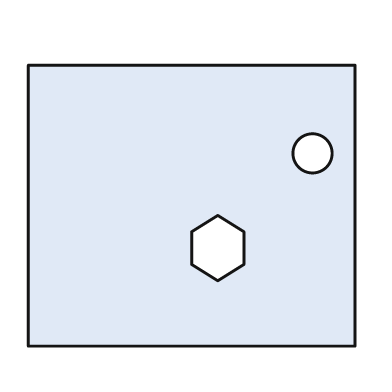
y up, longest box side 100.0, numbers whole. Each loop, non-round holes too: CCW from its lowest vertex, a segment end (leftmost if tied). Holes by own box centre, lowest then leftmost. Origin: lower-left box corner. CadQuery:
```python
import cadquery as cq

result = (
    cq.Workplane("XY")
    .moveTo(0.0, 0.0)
    .lineTo(100.0, 0.0)
    .lineTo(100.0, 86.0)
    .lineTo(0.0, 86.0)
    .close()
    .moveTo(58.0, 20.0)
    .lineTo(66.0, 25.0)
    .lineTo(66.0, 35.0)
    .lineTo(58.0, 40.0)
    .lineTo(50.0, 35.0)
    .lineTo(50.0, 25.0)
    .close()
    .moveTo(87.0, 59.0)
    .circle(6.0)
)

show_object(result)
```